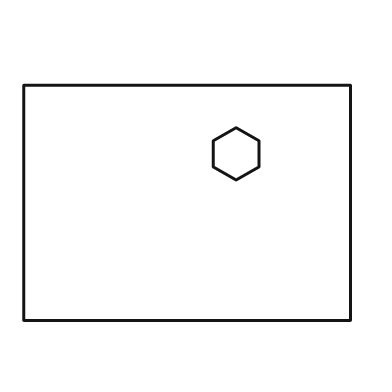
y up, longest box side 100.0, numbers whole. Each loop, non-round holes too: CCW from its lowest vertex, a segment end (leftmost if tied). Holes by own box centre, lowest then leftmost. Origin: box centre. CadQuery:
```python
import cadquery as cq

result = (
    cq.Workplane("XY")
    .moveTo(-50.0, -36.0)
    .lineTo(50.0, -36.0)
    .lineTo(50.0, 36.0)
    .lineTo(-50.0, 36.0)
    .close()
    .moveTo(15.0, 7.0)
    .lineTo(22.0, 11.0)
    .lineTo(22.0, 19.0)
    .lineTo(15.0, 23.0)
    .lineTo(8.0, 19.0)
    .lineTo(8.0, 11.0)
    .close()
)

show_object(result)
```